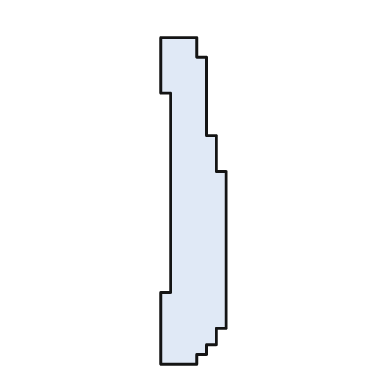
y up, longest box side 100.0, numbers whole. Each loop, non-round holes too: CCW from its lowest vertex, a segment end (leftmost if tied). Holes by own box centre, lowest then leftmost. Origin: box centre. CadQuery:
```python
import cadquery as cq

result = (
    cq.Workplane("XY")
    .moveTo(-10.0, -50.0)
    .lineTo(1.0, -50.0)
    .lineTo(1.0, -47.0)
    .lineTo(4.0, -47.0)
    .lineTo(4.0, -44.0)
    .lineTo(7.0, -44.0)
    .lineTo(7.0, -39.0)
    .lineTo(10.0, -39.0)
    .lineTo(10.0, 9.0)
    .lineTo(7.0, 9.0)
    .lineTo(7.0, 20.0)
    .lineTo(4.0, 20.0)
    .lineTo(4.0, 44.0)
    .lineTo(1.0, 44.0)
    .lineTo(1.0, 50.0)
    .lineTo(-10.0, 50.0)
    .lineTo(-10.0, 33.0)
    .lineTo(-7.0, 33.0)
    .lineTo(-7.0, -28.0)
    .lineTo(-10.0, -28.0)
    .close()
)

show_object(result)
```